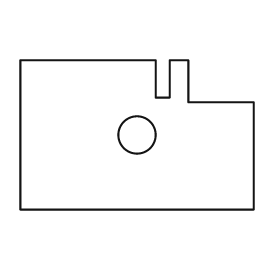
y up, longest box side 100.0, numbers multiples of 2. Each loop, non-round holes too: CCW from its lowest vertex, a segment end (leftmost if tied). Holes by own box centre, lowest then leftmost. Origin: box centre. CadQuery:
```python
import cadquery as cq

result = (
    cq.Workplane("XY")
    .moveTo(-50.0, -32.0)
    .lineTo(50.0, -32.0)
    .lineTo(50.0, 14.0)
    .lineTo(22.0, 14.0)
    .lineTo(22.0, 32.0)
    .lineTo(14.0, 32.0)
    .lineTo(14.0, 16.0)
    .lineTo(8.0, 16.0)
    .lineTo(8.0, 32.0)
    .lineTo(-50.0, 32.0)
    .close()
    .moveTo(0.0, 0.0)
    .circle(8.0)
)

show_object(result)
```